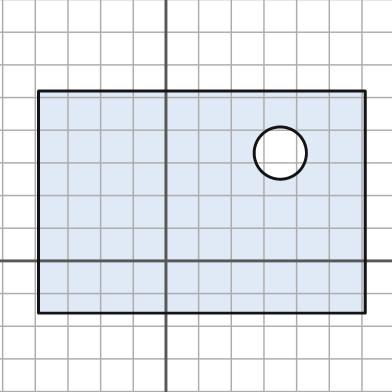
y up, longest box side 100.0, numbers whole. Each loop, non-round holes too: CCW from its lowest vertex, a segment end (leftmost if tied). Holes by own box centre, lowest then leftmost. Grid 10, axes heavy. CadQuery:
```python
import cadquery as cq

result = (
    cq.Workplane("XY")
    .moveTo(-39.0, -16.0)
    .lineTo(61.0, -16.0)
    .lineTo(61.0, 52.0)
    .lineTo(-39.0, 52.0)
    .close()
    .moveTo(35.0, 33.0)
    .circle(8.0)
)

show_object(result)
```